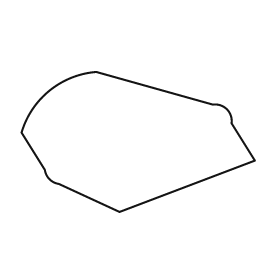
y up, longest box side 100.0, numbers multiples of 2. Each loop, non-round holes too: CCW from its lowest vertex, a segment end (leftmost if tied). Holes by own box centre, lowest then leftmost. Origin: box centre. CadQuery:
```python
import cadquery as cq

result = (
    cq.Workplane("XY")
    .moveTo(-8.0, -30.0)
    .lineTo(50.0, -8.0)
    .lineTo(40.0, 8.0)
    .threePointArc((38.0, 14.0), (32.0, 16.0))
    .lineTo(-18.0, 30.0)
    .threePointArc((-38.0, 22.0), (-50.0, 4.0))
    .lineTo(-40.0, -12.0)
    .threePointArc((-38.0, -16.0), (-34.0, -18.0))
    .close()
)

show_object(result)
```